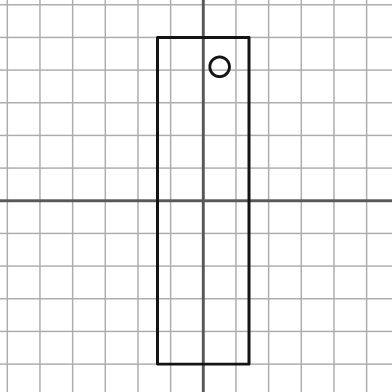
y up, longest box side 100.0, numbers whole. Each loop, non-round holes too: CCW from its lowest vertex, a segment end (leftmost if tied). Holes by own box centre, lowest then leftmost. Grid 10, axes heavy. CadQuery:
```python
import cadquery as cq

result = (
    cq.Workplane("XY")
    .moveTo(-14.0, -50.0)
    .lineTo(14.0, -50.0)
    .lineTo(14.0, 50.0)
    .lineTo(-14.0, 50.0)
    .close()
    .moveTo(5.0, 41.0)
    .circle(3.0)
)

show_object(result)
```